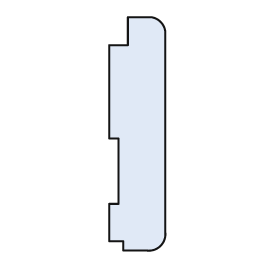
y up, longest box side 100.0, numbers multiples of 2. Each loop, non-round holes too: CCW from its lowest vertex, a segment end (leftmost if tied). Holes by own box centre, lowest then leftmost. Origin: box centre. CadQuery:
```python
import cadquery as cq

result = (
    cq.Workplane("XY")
    .moveTo(-6.0, -50.0)
    .lineTo(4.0, -50.0)
    .threePointArc((10.0, -48.0), (12.0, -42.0))
    .lineTo(12.0, 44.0)
    .threePointArc((10.0, 48.0), (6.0, 50.0))
    .lineTo(-4.0, 50.0)
    .lineTo(-4.0, 38.0)
    .lineTo(-12.0, 38.0)
    .lineTo(-12.0, -2.0)
    .lineTo(-8.0, -2.0)
    .lineTo(-8.0, -30.0)
    .lineTo(-12.0, -30.0)
    .lineTo(-12.0, -46.0)
    .lineTo(-6.0, -46.0)
    .close()
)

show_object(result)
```